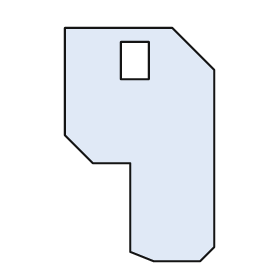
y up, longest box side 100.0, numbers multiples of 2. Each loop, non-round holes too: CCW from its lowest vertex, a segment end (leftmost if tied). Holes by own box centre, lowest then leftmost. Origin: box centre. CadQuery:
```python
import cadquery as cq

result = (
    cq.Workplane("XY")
    .moveTo(6.0, -50.0)
    .lineTo(26.0, -50.0)
    .lineTo(32.0, -44.0)
    .lineTo(32.0, 32.0)
    .lineTo(14.0, 50.0)
    .lineTo(-32.0, 50.0)
    .lineTo(-32.0, 4.0)
    .lineTo(-20.0, -8.0)
    .lineTo(-4.0, -8.0)
    .lineTo(-4.0, -46.0)
    .close()
    .moveTo(-8.0, 28.0)
    .lineTo(4.0, 28.0)
    .lineTo(4.0, 44.0)
    .lineTo(-8.0, 44.0)
    .close()
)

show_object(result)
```